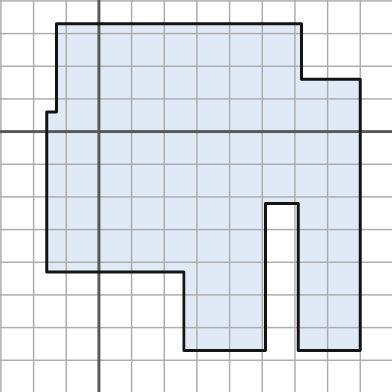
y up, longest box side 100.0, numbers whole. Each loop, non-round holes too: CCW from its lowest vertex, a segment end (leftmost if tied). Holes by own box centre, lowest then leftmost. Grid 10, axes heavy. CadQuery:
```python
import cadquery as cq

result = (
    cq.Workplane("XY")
    .moveTo(26.0, -67.0)
    .lineTo(51.0, -67.0)
    .lineTo(51.0, -22.0)
    .lineTo(61.0, -22.0)
    .lineTo(61.0, -67.0)
    .lineTo(80.0, -67.0)
    .lineTo(80.0, 16.0)
    .lineTo(62.0, 16.0)
    .lineTo(62.0, 33.0)
    .lineTo(-13.0, 33.0)
    .lineTo(-13.0, 6.0)
    .lineTo(-16.0, 6.0)
    .lineTo(-16.0, -43.0)
    .lineTo(26.0, -43.0)
    .close()
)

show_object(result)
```